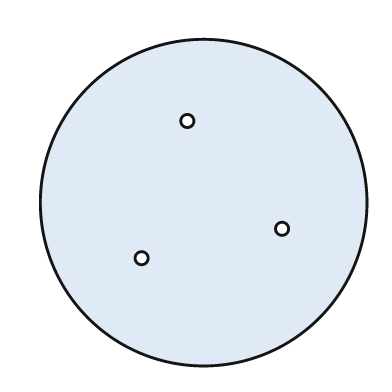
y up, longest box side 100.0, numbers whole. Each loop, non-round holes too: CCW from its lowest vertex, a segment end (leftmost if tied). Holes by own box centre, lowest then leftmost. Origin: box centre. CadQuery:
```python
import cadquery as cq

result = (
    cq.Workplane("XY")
    .moveTo(0.0, 0.0)
    .circle(50.0)
    .moveTo(-19.0, -17.0)
    .circle(2.0)
    .moveTo(24.0, -8.0)
    .circle(2.0)
    .moveTo(-5.0, 25.0)
    .circle(2.0)
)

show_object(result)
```